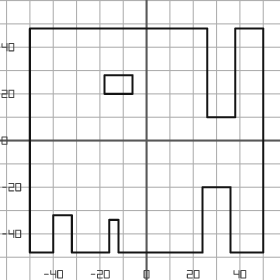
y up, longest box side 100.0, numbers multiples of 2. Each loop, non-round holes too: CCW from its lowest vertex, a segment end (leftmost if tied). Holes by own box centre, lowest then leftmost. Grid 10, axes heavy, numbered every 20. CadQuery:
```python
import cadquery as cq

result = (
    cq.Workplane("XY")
    .moveTo(-50.0, -48.0)
    .lineTo(-40.0, -48.0)
    .lineTo(-40.0, -32.0)
    .lineTo(-32.0, -32.0)
    .lineTo(-32.0, -48.0)
    .lineTo(-16.0, -48.0)
    .lineTo(-16.0, -34.0)
    .lineTo(-12.0, -34.0)
    .lineTo(-12.0, -48.0)
    .lineTo(24.0, -48.0)
    .lineTo(24.0, -20.0)
    .lineTo(36.0, -20.0)
    .lineTo(36.0, -48.0)
    .lineTo(50.0, -48.0)
    .lineTo(50.0, 48.0)
    .lineTo(38.0, 48.0)
    .lineTo(38.0, 10.0)
    .lineTo(26.0, 10.0)
    .lineTo(26.0, 48.0)
    .lineTo(-50.0, 48.0)
    .close()
    .moveTo(-18.0, 20.0)
    .lineTo(-6.0, 20.0)
    .lineTo(-6.0, 28.0)
    .lineTo(-18.0, 28.0)
    .close()
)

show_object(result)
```